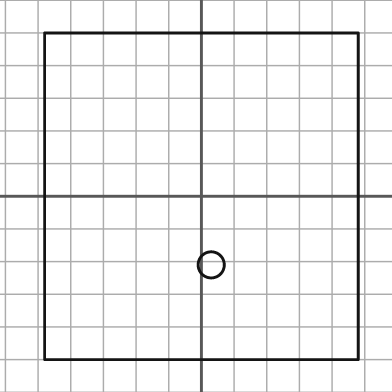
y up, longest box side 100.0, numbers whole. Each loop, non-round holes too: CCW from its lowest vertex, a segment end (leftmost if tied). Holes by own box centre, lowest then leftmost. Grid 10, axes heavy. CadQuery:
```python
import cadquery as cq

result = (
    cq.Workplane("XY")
    .moveTo(-48.0, -50.0)
    .lineTo(48.0, -50.0)
    .lineTo(48.0, 50.0)
    .lineTo(-48.0, 50.0)
    .close()
    .moveTo(3.0, -21.0)
    .circle(4.0)
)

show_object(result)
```